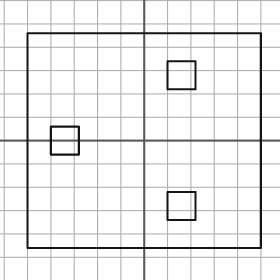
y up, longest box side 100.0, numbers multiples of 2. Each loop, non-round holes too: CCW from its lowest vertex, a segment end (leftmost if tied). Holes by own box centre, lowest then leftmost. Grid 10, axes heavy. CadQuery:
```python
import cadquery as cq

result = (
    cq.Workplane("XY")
    .moveTo(-50.0, -46.0)
    .lineTo(50.0, -46.0)
    .lineTo(50.0, 46.0)
    .lineTo(-50.0, 46.0)
    .close()
    .moveTo(10.0, -34.0)
    .lineTo(22.0, -34.0)
    .lineTo(22.0, -22.0)
    .lineTo(10.0, -22.0)
    .close()
    .moveTo(-40.0, -6.0)
    .lineTo(-28.0, -6.0)
    .lineTo(-28.0, 6.0)
    .lineTo(-40.0, 6.0)
    .close()
    .moveTo(10.0, 22.0)
    .lineTo(22.0, 22.0)
    .lineTo(22.0, 34.0)
    .lineTo(10.0, 34.0)
    .close()
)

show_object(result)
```